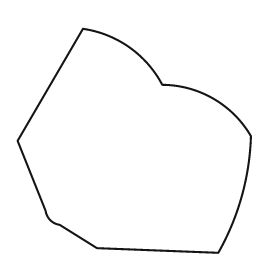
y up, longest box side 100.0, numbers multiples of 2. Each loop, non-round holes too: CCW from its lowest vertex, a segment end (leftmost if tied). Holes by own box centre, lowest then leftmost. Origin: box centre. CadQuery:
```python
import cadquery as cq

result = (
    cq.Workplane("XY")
    .moveTo(36.0, -48.0)
    .threePointArc((46.0, -24.0), (50.0, 2.0))
    .threePointArc((34.0, 18.0), (12.0, 24.0))
    .threePointArc((-2.0, 40.0), (-22.0, 48.0))
    .lineTo(-50.0, 0.0)
    .lineTo(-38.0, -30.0)
    .threePointArc((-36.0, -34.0), (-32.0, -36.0))
    .lineTo(-16.0, -46.0)
    .close()
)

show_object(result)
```